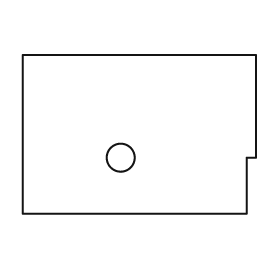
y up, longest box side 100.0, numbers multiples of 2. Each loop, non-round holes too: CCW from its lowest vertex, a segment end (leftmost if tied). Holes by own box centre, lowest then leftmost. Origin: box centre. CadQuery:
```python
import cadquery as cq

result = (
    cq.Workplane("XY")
    .moveTo(-50.0, -34.0)
    .lineTo(46.0, -34.0)
    .lineTo(46.0, -10.0)
    .lineTo(50.0, -10.0)
    .lineTo(50.0, 34.0)
    .lineTo(-50.0, 34.0)
    .close()
    .moveTo(-8.0, -10.0)
    .circle(6.0)
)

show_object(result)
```